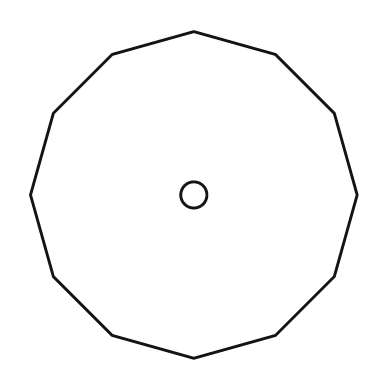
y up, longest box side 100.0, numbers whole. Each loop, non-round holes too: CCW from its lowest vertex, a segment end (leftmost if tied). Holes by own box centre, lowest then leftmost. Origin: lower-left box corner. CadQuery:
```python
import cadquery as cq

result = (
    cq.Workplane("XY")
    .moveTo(50.0, 0.0)
    .lineTo(75.0, 7.0)
    .lineTo(93.0, 25.0)
    .lineTo(100.0, 50.0)
    .lineTo(93.0, 75.0)
    .lineTo(75.0, 93.0)
    .lineTo(50.0, 100.0)
    .lineTo(25.0, 93.0)
    .lineTo(7.0, 75.0)
    .lineTo(0.0, 50.0)
    .lineTo(7.0, 25.0)
    .lineTo(25.0, 7.0)
    .close()
    .moveTo(50.0, 50.0)
    .circle(4.0)
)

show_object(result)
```